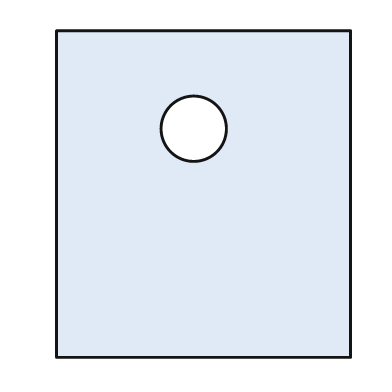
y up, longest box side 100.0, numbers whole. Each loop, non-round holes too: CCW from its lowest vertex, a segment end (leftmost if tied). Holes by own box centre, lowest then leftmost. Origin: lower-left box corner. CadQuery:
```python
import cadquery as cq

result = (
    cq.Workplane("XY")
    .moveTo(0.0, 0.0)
    .lineTo(90.0, 0.0)
    .lineTo(90.0, 100.0)
    .lineTo(0.0, 100.0)
    .close()
    .moveTo(42.0, 70.0)
    .circle(10.0)
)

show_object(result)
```